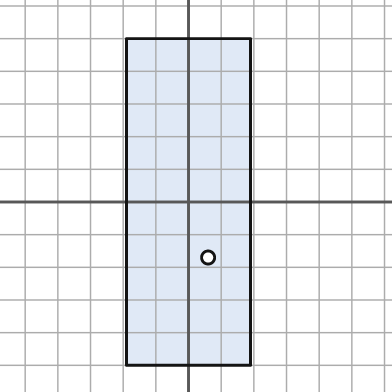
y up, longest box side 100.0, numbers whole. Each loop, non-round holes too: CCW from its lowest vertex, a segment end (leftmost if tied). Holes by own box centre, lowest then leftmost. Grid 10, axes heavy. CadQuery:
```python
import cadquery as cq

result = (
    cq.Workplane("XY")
    .moveTo(-19.0, -50.0)
    .lineTo(19.0, -50.0)
    .lineTo(19.0, 50.0)
    .lineTo(-19.0, 50.0)
    .close()
    .moveTo(6.0, -17.0)
    .circle(2.0)
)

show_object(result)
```